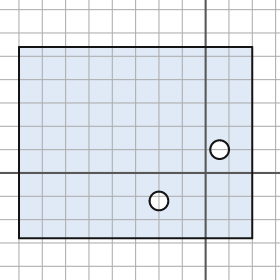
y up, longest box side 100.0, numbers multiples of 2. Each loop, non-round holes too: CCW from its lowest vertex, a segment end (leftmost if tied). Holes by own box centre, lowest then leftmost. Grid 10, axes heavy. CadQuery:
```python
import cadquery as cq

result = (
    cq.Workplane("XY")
    .moveTo(-80.0, -28.0)
    .lineTo(20.0, -28.0)
    .lineTo(20.0, 54.0)
    .lineTo(-80.0, 54.0)
    .close()
    .moveTo(-20.0, -12.0)
    .circle(4.0)
    .moveTo(6.0, 10.0)
    .circle(4.0)
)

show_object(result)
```